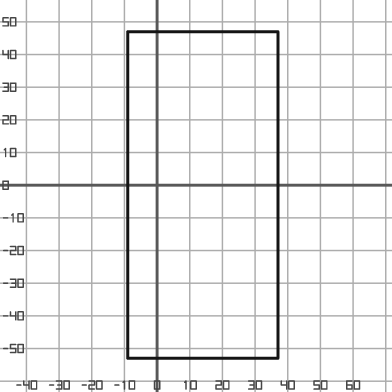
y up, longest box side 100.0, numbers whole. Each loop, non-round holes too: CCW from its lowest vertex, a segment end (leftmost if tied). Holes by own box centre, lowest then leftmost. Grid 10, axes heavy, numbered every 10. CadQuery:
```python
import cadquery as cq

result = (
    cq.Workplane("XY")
    .moveTo(-9.0, -53.0)
    .lineTo(37.0, -53.0)
    .lineTo(37.0, 47.0)
    .lineTo(-9.0, 47.0)
    .close()
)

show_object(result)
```